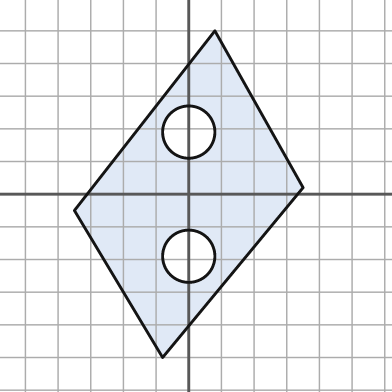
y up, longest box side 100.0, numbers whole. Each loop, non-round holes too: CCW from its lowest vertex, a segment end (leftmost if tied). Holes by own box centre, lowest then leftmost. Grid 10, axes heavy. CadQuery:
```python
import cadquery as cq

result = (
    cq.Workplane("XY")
    .moveTo(-8.0, -50.0)
    .lineTo(35.0, 2.0)
    .lineTo(8.0, 50.0)
    .lineTo(-35.0, -5.0)
    .close()
    .moveTo(0.0, -19.0)
    .circle(8.0)
    .moveTo(0.0, 19.0)
    .circle(8.0)
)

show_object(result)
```